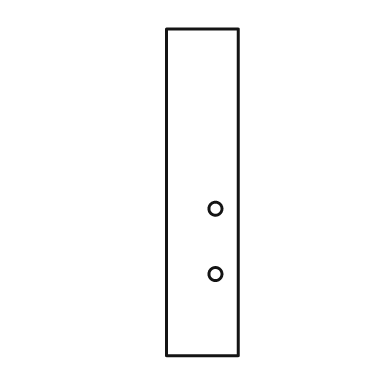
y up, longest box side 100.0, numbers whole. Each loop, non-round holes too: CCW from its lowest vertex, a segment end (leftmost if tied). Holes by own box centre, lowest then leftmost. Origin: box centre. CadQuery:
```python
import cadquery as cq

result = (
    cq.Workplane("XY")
    .moveTo(-11.0, -50.0)
    .lineTo(11.0, -50.0)
    .lineTo(11.0, 50.0)
    .lineTo(-11.0, 50.0)
    .close()
    .moveTo(4.0, -25.0)
    .circle(2.0)
    .moveTo(4.0, -5.0)
    .circle(2.0)
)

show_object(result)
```